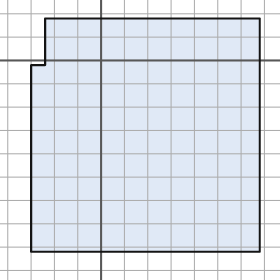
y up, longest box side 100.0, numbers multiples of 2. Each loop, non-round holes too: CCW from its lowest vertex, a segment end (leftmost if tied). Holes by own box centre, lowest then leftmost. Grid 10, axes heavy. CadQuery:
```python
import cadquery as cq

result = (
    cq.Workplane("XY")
    .moveTo(-30.0, -82.0)
    .lineTo(68.0, -82.0)
    .lineTo(68.0, 18.0)
    .lineTo(-24.0, 18.0)
    .lineTo(-24.0, -2.0)
    .lineTo(-30.0, -2.0)
    .close()
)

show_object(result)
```